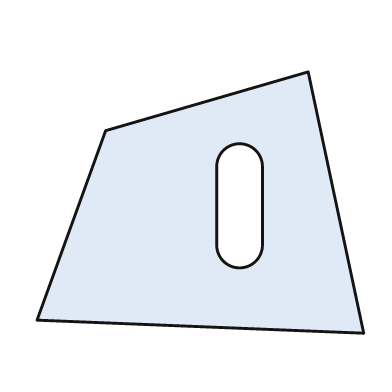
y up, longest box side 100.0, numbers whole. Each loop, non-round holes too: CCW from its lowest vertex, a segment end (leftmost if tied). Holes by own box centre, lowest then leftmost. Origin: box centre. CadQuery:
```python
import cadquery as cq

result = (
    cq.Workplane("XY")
    .moveTo(50.0, -40.0)
    .lineTo(33.0, 40.0)
    .lineTo(-29.0, 22.0)
    .lineTo(-50.0, -36.0)
    .close()
    .moveTo(5.0, -13.0)
    .threePointArc((12.0, -20.0), (19.0, -13.0))
    .lineTo(19.0, 11.0)
    .threePointArc((12.0, 18.0), (5.0, 11.0))
    .close()
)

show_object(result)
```